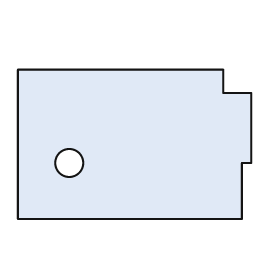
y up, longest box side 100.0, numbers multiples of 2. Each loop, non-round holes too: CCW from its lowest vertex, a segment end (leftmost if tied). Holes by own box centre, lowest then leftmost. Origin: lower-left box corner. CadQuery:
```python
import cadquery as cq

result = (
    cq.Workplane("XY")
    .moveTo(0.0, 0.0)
    .lineTo(96.0, 0.0)
    .lineTo(96.0, 24.0)
    .lineTo(100.0, 24.0)
    .lineTo(100.0, 54.0)
    .lineTo(88.0, 54.0)
    .lineTo(88.0, 64.0)
    .lineTo(0.0, 64.0)
    .close()
    .moveTo(22.0, 24.0)
    .circle(6.0)
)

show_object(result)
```